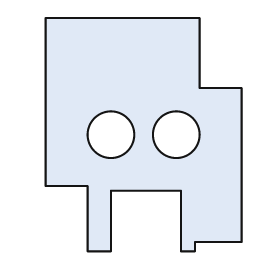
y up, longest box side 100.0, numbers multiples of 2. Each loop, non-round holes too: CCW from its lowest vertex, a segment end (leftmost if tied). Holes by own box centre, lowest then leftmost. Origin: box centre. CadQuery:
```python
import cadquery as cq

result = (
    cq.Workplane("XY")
    .moveTo(-24.0, -50.0)
    .lineTo(-14.0, -50.0)
    .lineTo(-14.0, -24.0)
    .lineTo(16.0, -24.0)
    .lineTo(16.0, -50.0)
    .lineTo(22.0, -50.0)
    .lineTo(22.0, -46.0)
    .lineTo(42.0, -46.0)
    .lineTo(42.0, 20.0)
    .lineTo(24.0, 20.0)
    .lineTo(24.0, 50.0)
    .lineTo(-42.0, 50.0)
    .lineTo(-42.0, -22.0)
    .lineTo(-24.0, -22.0)
    .close()
    .moveTo(-14.0, 0.0)
    .circle(10.0)
    .moveTo(14.0, 0.0)
    .circle(10.0)
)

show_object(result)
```